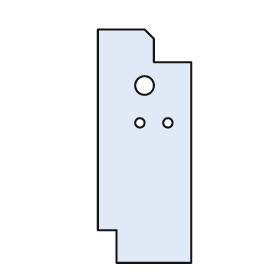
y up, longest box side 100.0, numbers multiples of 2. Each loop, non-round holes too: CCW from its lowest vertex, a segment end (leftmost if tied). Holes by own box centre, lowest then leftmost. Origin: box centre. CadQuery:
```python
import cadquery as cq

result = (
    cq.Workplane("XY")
    .moveTo(-12.0, -50.0)
    .lineTo(20.0, -50.0)
    .lineTo(20.0, 36.0)
    .lineTo(4.0, 36.0)
    .lineTo(4.0, 46.0)
    .lineTo(0.0, 50.0)
    .lineTo(-20.0, 50.0)
    .lineTo(-20.0, -36.0)
    .lineTo(-12.0, -36.0)
    .close()
    .moveTo(-2.0, 10.0)
    .circle(2.0)
    .moveTo(10.0, 10.0)
    .circle(2.0)
    .moveTo(0.0, 26.0)
    .circle(4.0)
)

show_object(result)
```